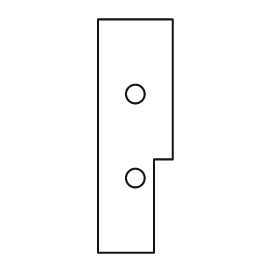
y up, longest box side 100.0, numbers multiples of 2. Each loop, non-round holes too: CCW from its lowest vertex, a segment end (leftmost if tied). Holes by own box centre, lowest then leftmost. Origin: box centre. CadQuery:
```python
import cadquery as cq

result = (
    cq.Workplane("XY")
    .moveTo(-16.0, -50.0)
    .lineTo(8.0, -50.0)
    .lineTo(8.0, -10.0)
    .lineTo(16.0, -10.0)
    .lineTo(16.0, 50.0)
    .lineTo(-16.0, 50.0)
    .close()
    .moveTo(0.0, -18.0)
    .circle(4.0)
    .moveTo(0.0, 18.0)
    .circle(4.0)
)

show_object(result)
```